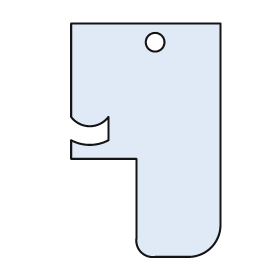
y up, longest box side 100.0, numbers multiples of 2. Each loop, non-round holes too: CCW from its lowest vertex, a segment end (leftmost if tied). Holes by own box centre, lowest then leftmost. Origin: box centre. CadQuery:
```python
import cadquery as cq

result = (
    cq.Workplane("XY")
    .moveTo(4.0, -50.0)
    .lineTo(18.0, -50.0)
    .threePointArc((28.0, -46.0), (32.0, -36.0))
    .lineTo(32.0, 50.0)
    .lineTo(-32.0, 50.0)
    .lineTo(-32.0, 10.0)
    .threePointArc((-24.0, 6.0), (-16.0, 10.0))
    .lineTo(-16.0, 0.0)
    .threePointArc((-24.0, -2.0), (-32.0, 0.0))
    .lineTo(-32.0, -8.0)
    .lineTo(-4.0, -8.0)
    .lineTo(-4.0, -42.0)
    .threePointArc((-2.0, -48.0), (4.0, -50.0))
    .close()
    .moveTo(4.0, 42.0)
    .circle(4.0)
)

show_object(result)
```